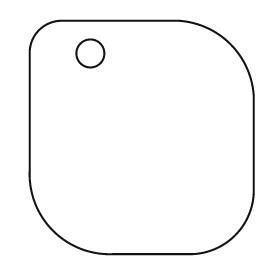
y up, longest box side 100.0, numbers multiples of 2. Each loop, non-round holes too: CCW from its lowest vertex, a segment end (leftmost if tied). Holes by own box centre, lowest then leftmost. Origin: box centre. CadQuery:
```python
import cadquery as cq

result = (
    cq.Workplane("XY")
    .moveTo(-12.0, -50.0)
    .lineTo(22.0, -50.0)
    .threePointArc((40.0, -42.0), (48.0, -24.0))
    .lineTo(48.0, 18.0)
    .threePointArc((38.0, 40.0), (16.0, 50.0))
    .lineTo(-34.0, 50.0)
    .threePointArc((-44.0, 46.0), (-48.0, 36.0))
    .lineTo(-48.0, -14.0)
    .threePointArc((-38.0, -40.0), (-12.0, -50.0))
    .close()
    .moveTo(-22.0, 36.0)
    .circle(6.0)
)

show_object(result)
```